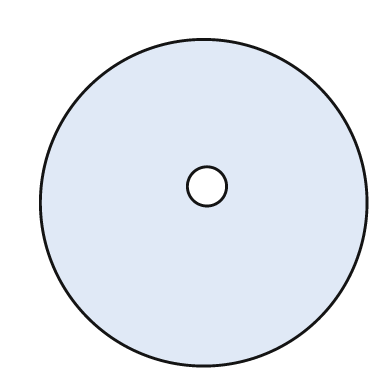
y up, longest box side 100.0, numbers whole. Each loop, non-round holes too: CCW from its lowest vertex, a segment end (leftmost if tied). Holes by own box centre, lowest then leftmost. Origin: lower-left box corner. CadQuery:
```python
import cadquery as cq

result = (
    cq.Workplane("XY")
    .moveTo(50.0, 50.0)
    .circle(50.0)
    .moveTo(51.0, 55.0)
    .circle(6.0)
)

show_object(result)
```